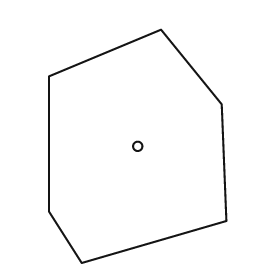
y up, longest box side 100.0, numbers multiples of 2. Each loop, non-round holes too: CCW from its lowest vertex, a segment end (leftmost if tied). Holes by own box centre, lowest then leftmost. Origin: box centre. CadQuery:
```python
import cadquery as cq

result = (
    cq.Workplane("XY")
    .moveTo(-24.0, -50.0)
    .lineTo(38.0, -32.0)
    .lineTo(36.0, 18.0)
    .lineTo(10.0, 50.0)
    .lineTo(-38.0, 30.0)
    .lineTo(-38.0, -28.0)
    .close()
    .moveTo(0.0, 0.0)
    .circle(2.0)
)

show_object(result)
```